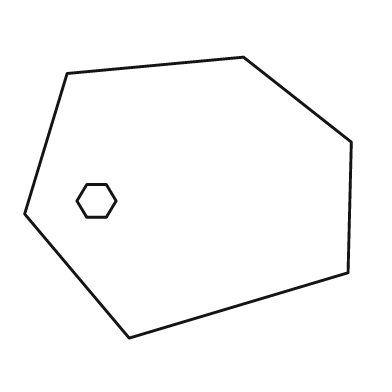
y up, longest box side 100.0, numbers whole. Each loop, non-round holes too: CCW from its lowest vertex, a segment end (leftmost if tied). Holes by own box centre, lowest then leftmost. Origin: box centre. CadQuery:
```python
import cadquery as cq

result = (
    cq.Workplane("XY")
    .moveTo(-18.0, -43.0)
    .lineTo(49.0, -23.0)
    .lineTo(50.0, 17.0)
    .lineTo(17.0, 43.0)
    .lineTo(-37.0, 38.0)
    .lineTo(-50.0, -5.0)
    .close()
    .moveTo(-31.0, -6.0)
    .lineTo(-25.0, -6.0)
    .lineTo(-22.0, -1.0)
    .lineTo(-25.0, 4.0)
    .lineTo(-31.0, 4.0)
    .lineTo(-34.0, -1.0)
    .close()
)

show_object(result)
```